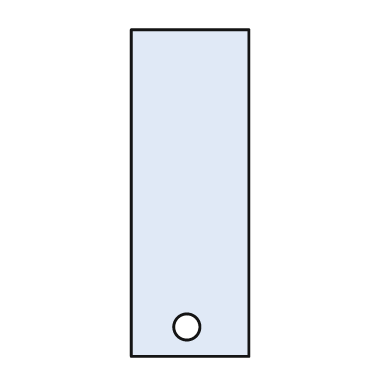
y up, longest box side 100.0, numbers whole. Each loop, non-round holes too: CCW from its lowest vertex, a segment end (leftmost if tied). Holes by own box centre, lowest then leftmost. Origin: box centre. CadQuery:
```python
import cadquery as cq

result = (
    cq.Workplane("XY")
    .moveTo(-18.0, -50.0)
    .lineTo(18.0, -50.0)
    .lineTo(18.0, 50.0)
    .lineTo(-18.0, 50.0)
    .close()
    .moveTo(-1.0, -41.0)
    .circle(4.0)
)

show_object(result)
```